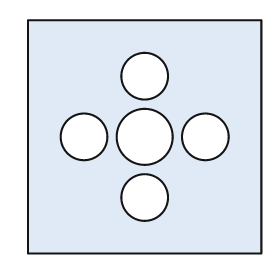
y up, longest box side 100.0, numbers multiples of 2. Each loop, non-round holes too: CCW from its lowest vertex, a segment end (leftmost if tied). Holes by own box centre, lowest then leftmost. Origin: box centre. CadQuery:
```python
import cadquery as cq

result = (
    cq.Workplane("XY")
    .moveTo(-50.0, -50.0)
    .lineTo(50.0, -50.0)
    .lineTo(50.0, 50.0)
    .lineTo(-50.0, 50.0)
    .close()
    .moveTo(0.0, -26.0)
    .circle(10.0)
    .moveTo(-26.0, 0.0)
    .circle(10.0)
    .moveTo(0.0, 0.0)
    .circle(12.0)
    .moveTo(26.0, 0.0)
    .circle(10.0)
    .moveTo(0.0, 26.0)
    .circle(10.0)
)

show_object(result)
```